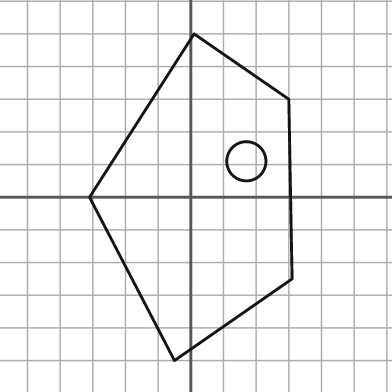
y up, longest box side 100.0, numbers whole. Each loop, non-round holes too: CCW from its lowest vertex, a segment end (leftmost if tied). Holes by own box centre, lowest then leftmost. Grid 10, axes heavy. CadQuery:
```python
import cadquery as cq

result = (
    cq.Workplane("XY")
    .moveTo(-5.0, -50.0)
    .lineTo(31.0, -25.0)
    .lineTo(30.0, 30.0)
    .lineTo(1.0, 50.0)
    .lineTo(-31.0, 0.0)
    .close()
    .moveTo(17.0, 11.0)
    .circle(6.0)
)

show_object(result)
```